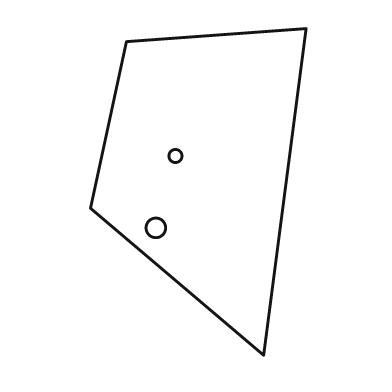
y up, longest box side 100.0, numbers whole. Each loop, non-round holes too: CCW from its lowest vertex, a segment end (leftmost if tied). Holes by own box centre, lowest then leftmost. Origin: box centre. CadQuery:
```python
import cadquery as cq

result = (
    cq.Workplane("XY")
    .moveTo(20.0, -50.0)
    .lineTo(33.0, 50.0)
    .lineTo(-22.0, 46.0)
    .lineTo(-33.0, -5.0)
    .close()
    .moveTo(-13.0, -11.0)
    .circle(3.0)
    .moveTo(-7.0, 11.0)
    .circle(2.0)
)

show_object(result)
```